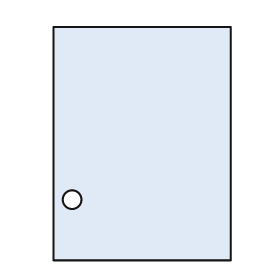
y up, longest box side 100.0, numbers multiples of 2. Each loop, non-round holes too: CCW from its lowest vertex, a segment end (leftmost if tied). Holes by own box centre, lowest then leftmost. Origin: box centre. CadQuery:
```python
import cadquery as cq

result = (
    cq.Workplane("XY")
    .moveTo(-38.0, -50.0)
    .lineTo(38.0, -50.0)
    .lineTo(38.0, 50.0)
    .lineTo(-38.0, 50.0)
    .close()
    .moveTo(-30.0, -24.0)
    .circle(4.0)
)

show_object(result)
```